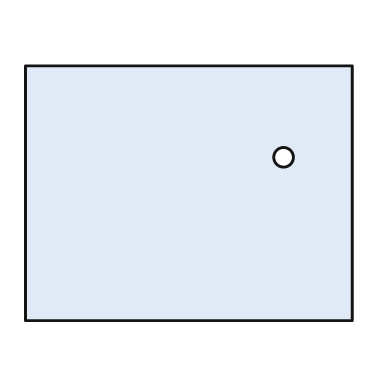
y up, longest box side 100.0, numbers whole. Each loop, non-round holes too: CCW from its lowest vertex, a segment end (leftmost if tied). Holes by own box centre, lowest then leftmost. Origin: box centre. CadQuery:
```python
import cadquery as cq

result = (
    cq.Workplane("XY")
    .moveTo(-50.0, -39.0)
    .lineTo(50.0, -39.0)
    .lineTo(50.0, 39.0)
    .lineTo(-50.0, 39.0)
    .close()
    .moveTo(29.0, 11.0)
    .circle(3.0)
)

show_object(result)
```